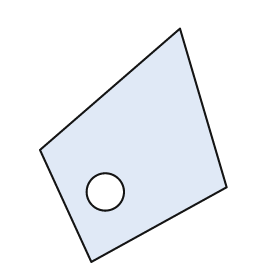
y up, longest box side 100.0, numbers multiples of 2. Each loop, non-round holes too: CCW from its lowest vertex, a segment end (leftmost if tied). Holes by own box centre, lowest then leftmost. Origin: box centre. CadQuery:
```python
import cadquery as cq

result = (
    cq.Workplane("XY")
    .moveTo(-18.0, -50.0)
    .lineTo(40.0, -18.0)
    .lineTo(20.0, 50.0)
    .lineTo(-40.0, -2.0)
    .close()
    .moveTo(-12.0, -20.0)
    .circle(8.0)
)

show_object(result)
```